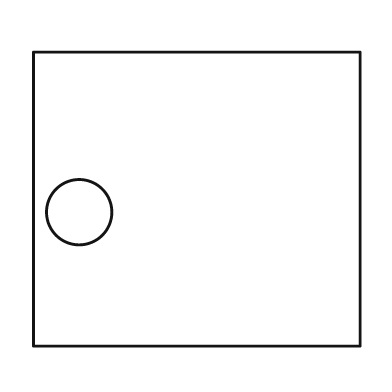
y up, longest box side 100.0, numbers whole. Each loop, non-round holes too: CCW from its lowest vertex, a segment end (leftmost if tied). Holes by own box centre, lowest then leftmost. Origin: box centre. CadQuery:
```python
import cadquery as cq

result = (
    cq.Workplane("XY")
    .moveTo(-50.0, -45.0)
    .lineTo(50.0, -45.0)
    .lineTo(50.0, 45.0)
    .lineTo(-50.0, 45.0)
    .close()
    .moveTo(-36.0, -4.0)
    .circle(10.0)
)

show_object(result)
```